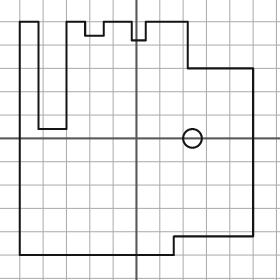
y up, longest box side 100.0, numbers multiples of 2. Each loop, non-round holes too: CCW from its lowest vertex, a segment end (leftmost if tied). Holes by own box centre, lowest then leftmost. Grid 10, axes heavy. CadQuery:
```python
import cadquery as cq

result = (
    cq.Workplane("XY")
    .moveTo(-50.0, -50.0)
    .lineTo(16.0, -50.0)
    .lineTo(16.0, -42.0)
    .lineTo(50.0, -42.0)
    .lineTo(50.0, 30.0)
    .lineTo(22.0, 30.0)
    .lineTo(22.0, 50.0)
    .lineTo(4.0, 50.0)
    .lineTo(4.0, 42.0)
    .lineTo(-2.0, 42.0)
    .lineTo(-2.0, 50.0)
    .lineTo(-14.0, 50.0)
    .lineTo(-14.0, 44.0)
    .lineTo(-22.0, 44.0)
    .lineTo(-22.0, 50.0)
    .lineTo(-30.0, 50.0)
    .lineTo(-30.0, 4.0)
    .lineTo(-42.0, 4.0)
    .lineTo(-42.0, 50.0)
    .lineTo(-50.0, 50.0)
    .close()
    .moveTo(24.0, 0.0)
    .circle(4.0)
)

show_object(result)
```